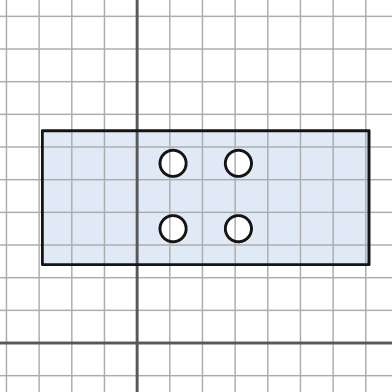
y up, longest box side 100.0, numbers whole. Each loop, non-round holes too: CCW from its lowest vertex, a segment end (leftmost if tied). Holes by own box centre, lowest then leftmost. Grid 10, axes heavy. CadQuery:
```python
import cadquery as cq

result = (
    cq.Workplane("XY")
    .moveTo(-29.0, 24.0)
    .lineTo(71.0, 24.0)
    .lineTo(71.0, 65.0)
    .lineTo(-29.0, 65.0)
    .close()
    .moveTo(11.0, 35.0)
    .circle(4.0)
    .moveTo(31.0, 35.0)
    .circle(4.0)
    .moveTo(11.0, 55.0)
    .circle(4.0)
    .moveTo(31.0, 55.0)
    .circle(4.0)
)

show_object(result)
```